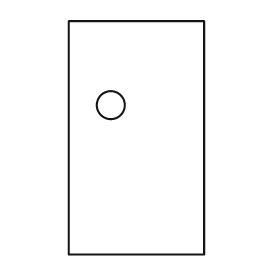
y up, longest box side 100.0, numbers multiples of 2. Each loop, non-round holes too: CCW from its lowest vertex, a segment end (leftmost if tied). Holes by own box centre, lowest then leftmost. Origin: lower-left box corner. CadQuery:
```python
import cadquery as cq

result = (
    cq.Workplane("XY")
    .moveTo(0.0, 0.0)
    .lineTo(58.0, 0.0)
    .lineTo(58.0, 100.0)
    .lineTo(0.0, 100.0)
    .close()
    .moveTo(18.0, 64.0)
    .circle(6.0)
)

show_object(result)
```